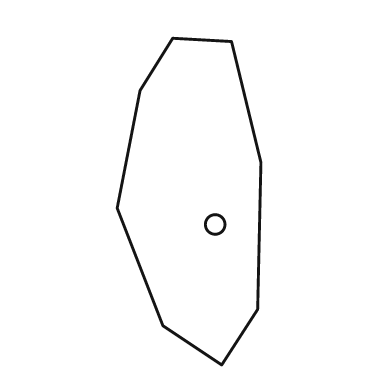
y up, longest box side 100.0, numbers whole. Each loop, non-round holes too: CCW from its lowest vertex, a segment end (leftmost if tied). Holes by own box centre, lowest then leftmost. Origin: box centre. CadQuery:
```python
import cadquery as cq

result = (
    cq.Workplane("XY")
    .moveTo(10.0, -50.0)
    .lineTo(21.0, -33.0)
    .lineTo(22.0, 12.0)
    .lineTo(13.0, 49.0)
    .lineTo(-5.0, 50.0)
    .lineTo(-15.0, 34.0)
    .lineTo(-22.0, -2.0)
    .lineTo(-8.0, -38.0)
    .close()
    .moveTo(8.0, -7.0)
    .circle(3.0)
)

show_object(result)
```